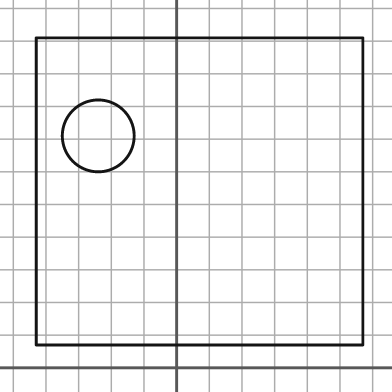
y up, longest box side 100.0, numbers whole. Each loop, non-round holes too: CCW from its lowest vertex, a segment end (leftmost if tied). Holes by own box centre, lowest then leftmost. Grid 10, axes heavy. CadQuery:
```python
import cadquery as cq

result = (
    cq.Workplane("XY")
    .moveTo(-43.0, 7.0)
    .lineTo(57.0, 7.0)
    .lineTo(57.0, 101.0)
    .lineTo(-43.0, 101.0)
    .close()
    .moveTo(-24.0, 71.0)
    .circle(11.0)
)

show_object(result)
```